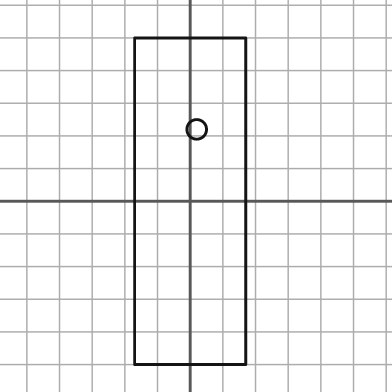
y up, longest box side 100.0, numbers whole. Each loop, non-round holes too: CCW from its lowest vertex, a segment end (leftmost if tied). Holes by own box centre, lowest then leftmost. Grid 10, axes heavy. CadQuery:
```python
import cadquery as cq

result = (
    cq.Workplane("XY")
    .moveTo(-17.0, -50.0)
    .lineTo(17.0, -50.0)
    .lineTo(17.0, 50.0)
    .lineTo(-17.0, 50.0)
    .close()
    .moveTo(2.0, 22.0)
    .circle(3.0)
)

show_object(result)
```